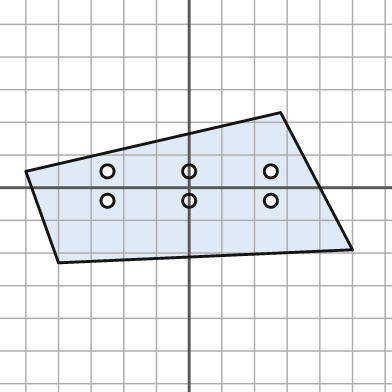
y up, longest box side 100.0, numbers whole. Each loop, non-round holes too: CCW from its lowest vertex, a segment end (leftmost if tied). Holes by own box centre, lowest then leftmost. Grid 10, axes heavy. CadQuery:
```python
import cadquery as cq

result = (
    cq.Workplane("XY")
    .moveTo(-40.0, -23.0)
    .lineTo(50.0, -19.0)
    .lineTo(28.0, 23.0)
    .lineTo(-50.0, 5.0)
    .close()
    .moveTo(-25.0, -4.0)
    .circle(2.0)
    .moveTo(0.0, -4.0)
    .circle(2.0)
    .moveTo(25.0, -4.0)
    .circle(2.0)
    .moveTo(-25.0, 5.0)
    .circle(2.0)
    .moveTo(0.0, 5.0)
    .circle(2.0)
    .moveTo(25.0, 5.0)
    .circle(2.0)
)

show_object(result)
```